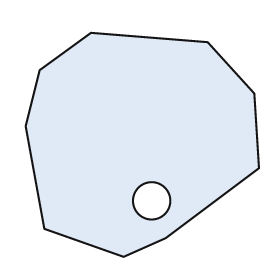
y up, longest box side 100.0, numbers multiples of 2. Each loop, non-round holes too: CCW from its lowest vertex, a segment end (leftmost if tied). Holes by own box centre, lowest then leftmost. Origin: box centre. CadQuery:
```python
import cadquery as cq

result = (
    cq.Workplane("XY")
    .moveTo(-8.0, -48.0)
    .lineTo(10.0, -40.0)
    .lineTo(50.0, -10.0)
    .lineTo(48.0, 22.0)
    .lineTo(28.0, 44.0)
    .lineTo(-22.0, 48.0)
    .lineTo(-44.0, 32.0)
    .lineTo(-50.0, 8.0)
    .lineTo(-42.0, -36.0)
    .close()
    .moveTo(4.0, -24.0)
    .circle(8.0)
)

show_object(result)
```